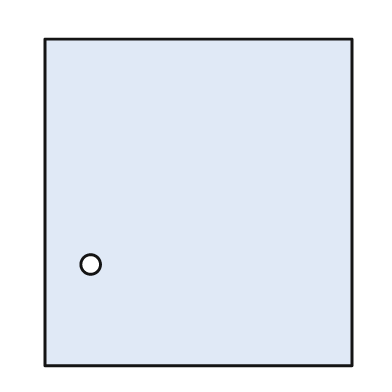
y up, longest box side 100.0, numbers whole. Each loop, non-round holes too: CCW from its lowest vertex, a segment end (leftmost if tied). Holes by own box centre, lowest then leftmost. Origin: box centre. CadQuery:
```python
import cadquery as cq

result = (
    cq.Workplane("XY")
    .moveTo(-47.0, -50.0)
    .lineTo(47.0, -50.0)
    .lineTo(47.0, 50.0)
    .lineTo(-47.0, 50.0)
    .close()
    .moveTo(-33.0, -19.0)
    .circle(3.0)
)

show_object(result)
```